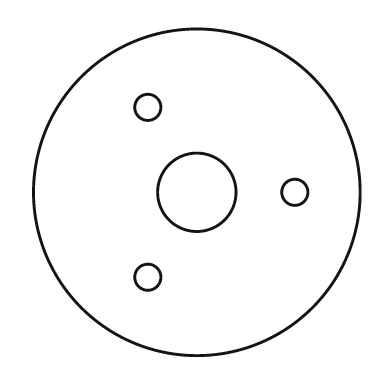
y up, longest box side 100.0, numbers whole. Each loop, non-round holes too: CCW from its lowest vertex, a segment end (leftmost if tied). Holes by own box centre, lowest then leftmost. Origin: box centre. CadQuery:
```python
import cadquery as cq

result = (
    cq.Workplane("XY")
    .moveTo(0.0, 0.0)
    .circle(50.0)
    .moveTo(-15.0, -26.0)
    .circle(4.0)
    .moveTo(0.0, 0.0)
    .circle(12.0)
    .moveTo(30.0, 0.0)
    .circle(4.0)
    .moveTo(-15.0, 26.0)
    .circle(4.0)
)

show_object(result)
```